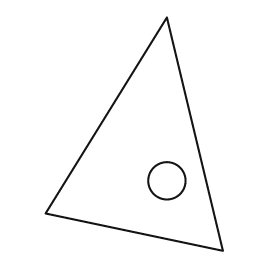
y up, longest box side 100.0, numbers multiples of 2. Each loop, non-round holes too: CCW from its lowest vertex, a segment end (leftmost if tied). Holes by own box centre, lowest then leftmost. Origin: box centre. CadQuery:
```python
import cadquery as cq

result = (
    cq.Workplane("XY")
    .moveTo(38.0, -50.0)
    .lineTo(14.0, 50.0)
    .lineTo(-38.0, -34.0)
    .close()
    .moveTo(14.0, -20.0)
    .circle(8.0)
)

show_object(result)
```